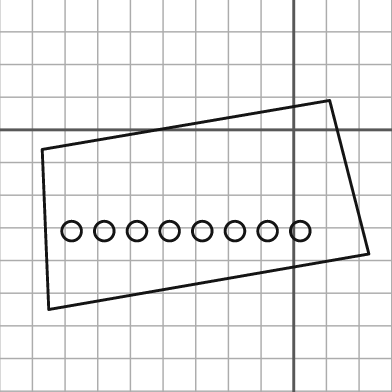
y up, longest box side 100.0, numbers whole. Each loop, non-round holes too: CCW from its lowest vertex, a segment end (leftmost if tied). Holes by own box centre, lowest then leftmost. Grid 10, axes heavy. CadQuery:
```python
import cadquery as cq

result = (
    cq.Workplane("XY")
    .moveTo(-75.0, -55.0)
    .lineTo(23.0, -38.0)
    .lineTo(11.0, 9.0)
    .lineTo(-77.0, -6.0)
    .close()
    .moveTo(-68.0, -31.0)
    .circle(3.0)
    .moveTo(-58.0, -31.0)
    .circle(3.0)
    .moveTo(-48.0, -31.0)
    .circle(3.0)
    .moveTo(-38.0, -31.0)
    .circle(3.0)
    .moveTo(-28.0, -31.0)
    .circle(3.0)
    .moveTo(-18.0, -31.0)
    .circle(3.0)
    .moveTo(-8.0, -31.0)
    .circle(3.0)
    .moveTo(2.0, -31.0)
    .circle(3.0)
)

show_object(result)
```